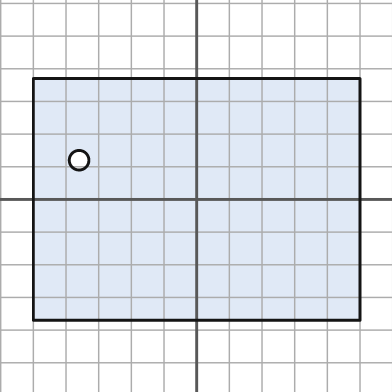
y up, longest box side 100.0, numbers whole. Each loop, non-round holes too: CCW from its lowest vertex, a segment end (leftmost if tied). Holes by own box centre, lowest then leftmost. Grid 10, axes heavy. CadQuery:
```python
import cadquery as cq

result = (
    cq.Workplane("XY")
    .moveTo(-50.0, -37.0)
    .lineTo(50.0, -37.0)
    .lineTo(50.0, 37.0)
    .lineTo(-50.0, 37.0)
    .close()
    .moveTo(-36.0, 12.0)
    .circle(3.0)
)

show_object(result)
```